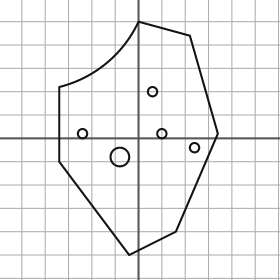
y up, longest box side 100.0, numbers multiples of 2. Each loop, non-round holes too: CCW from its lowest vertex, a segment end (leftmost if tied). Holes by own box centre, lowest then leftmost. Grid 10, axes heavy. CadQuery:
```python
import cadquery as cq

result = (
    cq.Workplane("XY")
    .moveTo(-4.0, -50.0)
    .lineTo(16.0, -40.0)
    .lineTo(34.0, 2.0)
    .lineTo(22.0, 44.0)
    .lineTo(0.0, 50.0)
    .threePointArc((-14.0, 32.0), (-34.0, 22.0))
    .lineTo(-34.0, -10.0)
    .close()
    .moveTo(-8.0, -8.0)
    .circle(4.0)
    .moveTo(24.0, -4.0)
    .circle(2.0)
    .moveTo(-24.0, 2.0)
    .circle(2.0)
    .moveTo(10.0, 2.0)
    .circle(2.0)
    .moveTo(6.0, 20.0)
    .circle(2.0)
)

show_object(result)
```